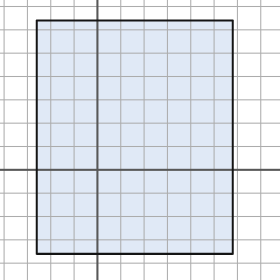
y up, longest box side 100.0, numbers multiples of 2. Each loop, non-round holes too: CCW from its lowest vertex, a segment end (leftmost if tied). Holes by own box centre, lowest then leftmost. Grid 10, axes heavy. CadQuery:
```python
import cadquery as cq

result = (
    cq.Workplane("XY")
    .moveTo(-26.0, -36.0)
    .lineTo(58.0, -36.0)
    .lineTo(58.0, 64.0)
    .lineTo(-26.0, 64.0)
    .close()
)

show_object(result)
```